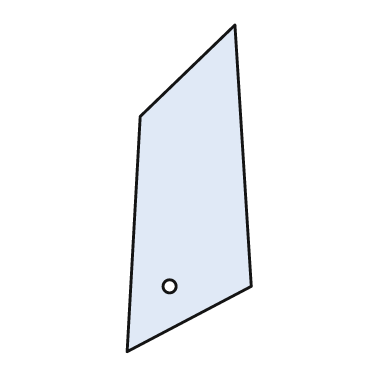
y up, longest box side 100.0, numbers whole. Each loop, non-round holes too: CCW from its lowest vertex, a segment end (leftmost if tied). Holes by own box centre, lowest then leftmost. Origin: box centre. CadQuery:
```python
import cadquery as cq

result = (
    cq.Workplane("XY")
    .moveTo(-19.0, -50.0)
    .lineTo(19.0, -30.0)
    .lineTo(14.0, 50.0)
    .lineTo(-15.0, 22.0)
    .close()
    .moveTo(-6.0, -30.0)
    .circle(2.0)
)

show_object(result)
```